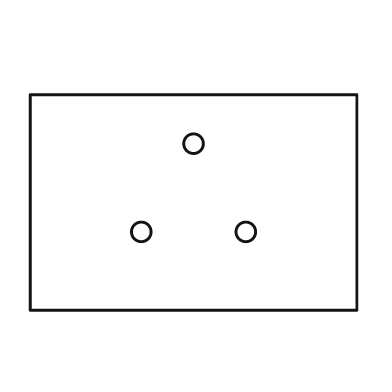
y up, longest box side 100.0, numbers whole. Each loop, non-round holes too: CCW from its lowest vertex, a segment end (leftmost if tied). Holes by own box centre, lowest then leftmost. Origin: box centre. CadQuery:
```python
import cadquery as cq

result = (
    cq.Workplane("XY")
    .moveTo(-50.0, -33.0)
    .lineTo(50.0, -33.0)
    .lineTo(50.0, 33.0)
    .lineTo(-50.0, 33.0)
    .close()
    .moveTo(-16.0, -9.0)
    .circle(3.0)
    .moveTo(16.0, -9.0)
    .circle(3.0)
    .moveTo(0.0, 18.0)
    .circle(3.0)
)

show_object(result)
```